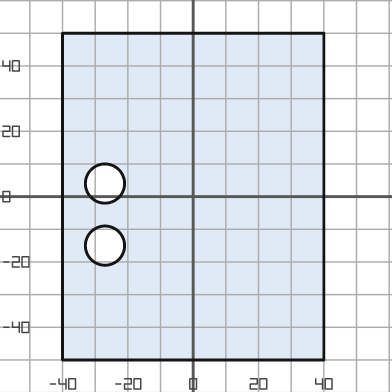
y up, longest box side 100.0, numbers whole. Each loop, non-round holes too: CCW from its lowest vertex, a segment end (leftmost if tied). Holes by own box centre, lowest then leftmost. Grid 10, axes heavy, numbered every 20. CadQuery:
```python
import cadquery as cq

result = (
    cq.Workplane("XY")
    .moveTo(-40.0, -50.0)
    .lineTo(40.0, -50.0)
    .lineTo(40.0, 50.0)
    .lineTo(-40.0, 50.0)
    .close()
    .moveTo(-27.0, -15.0)
    .circle(6.0)
    .moveTo(-27.0, 4.0)
    .circle(6.0)
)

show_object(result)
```